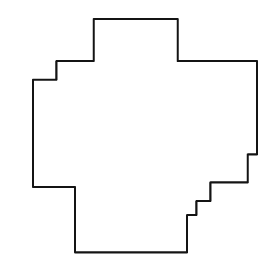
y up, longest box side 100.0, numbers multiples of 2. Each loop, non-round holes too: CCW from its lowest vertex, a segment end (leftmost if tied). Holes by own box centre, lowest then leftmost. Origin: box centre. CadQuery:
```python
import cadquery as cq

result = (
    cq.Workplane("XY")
    .moveTo(-30.0, -50.0)
    .lineTo(18.0, -50.0)
    .lineTo(18.0, -34.0)
    .lineTo(22.0, -34.0)
    .lineTo(22.0, -28.0)
    .lineTo(28.0, -28.0)
    .lineTo(28.0, -20.0)
    .lineTo(44.0, -20.0)
    .lineTo(44.0, -8.0)
    .lineTo(48.0, -8.0)
    .lineTo(48.0, 32.0)
    .lineTo(14.0, 32.0)
    .lineTo(14.0, 50.0)
    .lineTo(-22.0, 50.0)
    .lineTo(-22.0, 32.0)
    .lineTo(-38.0, 32.0)
    .lineTo(-38.0, 24.0)
    .lineTo(-48.0, 24.0)
    .lineTo(-48.0, -22.0)
    .lineTo(-30.0, -22.0)
    .close()
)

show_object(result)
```